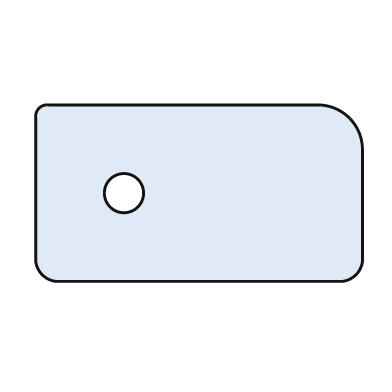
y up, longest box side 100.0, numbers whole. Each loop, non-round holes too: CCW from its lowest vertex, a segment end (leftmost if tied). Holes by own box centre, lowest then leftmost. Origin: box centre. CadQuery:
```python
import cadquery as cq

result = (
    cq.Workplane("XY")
    .moveTo(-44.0, -27.0)
    .lineTo(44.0, -27.0)
    .threePointArc((48.0, -25.0), (50.0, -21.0))
    .lineTo(50.0, 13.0)
    .threePointArc((46.0, 23.0), (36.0, 27.0))
    .lineTo(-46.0, 27.0)
    .threePointArc((-49.0, 26.0), (-50.0, 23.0))
    .lineTo(-50.0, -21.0)
    .threePointArc((-48.0, -25.0), (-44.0, -27.0))
    .close()
    .moveTo(-23.0, 0.0)
    .circle(6.0)
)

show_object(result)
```